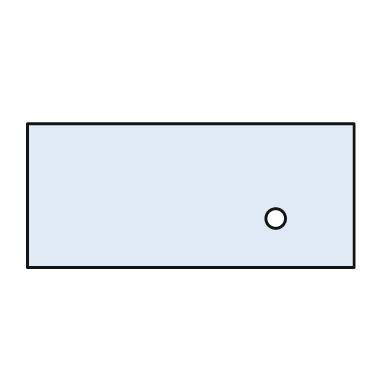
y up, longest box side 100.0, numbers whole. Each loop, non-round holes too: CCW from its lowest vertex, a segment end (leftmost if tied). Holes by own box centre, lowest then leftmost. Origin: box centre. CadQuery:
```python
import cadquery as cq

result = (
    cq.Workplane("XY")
    .moveTo(-50.0, -22.0)
    .lineTo(50.0, -22.0)
    .lineTo(50.0, 22.0)
    .lineTo(-50.0, 22.0)
    .close()
    .moveTo(26.0, -7.0)
    .circle(3.0)
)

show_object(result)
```